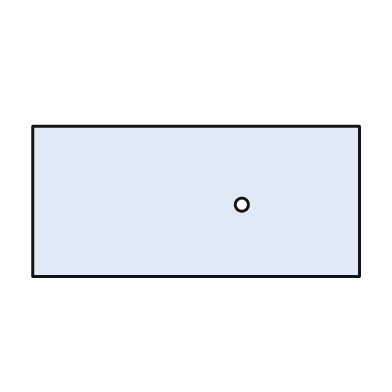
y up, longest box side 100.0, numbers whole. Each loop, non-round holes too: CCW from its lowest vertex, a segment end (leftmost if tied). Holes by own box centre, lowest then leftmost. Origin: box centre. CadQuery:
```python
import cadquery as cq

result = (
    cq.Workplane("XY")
    .moveTo(-50.0, -23.0)
    .lineTo(50.0, -23.0)
    .lineTo(50.0, 23.0)
    .lineTo(-50.0, 23.0)
    .close()
    .moveTo(14.0, -1.0)
    .circle(2.0)
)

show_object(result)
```